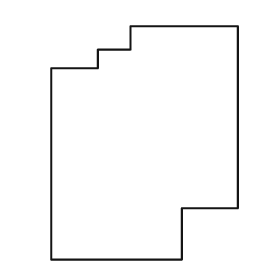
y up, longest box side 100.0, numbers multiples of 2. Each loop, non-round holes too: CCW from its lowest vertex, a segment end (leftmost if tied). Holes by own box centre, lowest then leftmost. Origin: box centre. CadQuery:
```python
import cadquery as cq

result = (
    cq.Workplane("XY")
    .moveTo(-40.0, -50.0)
    .lineTo(16.0, -50.0)
    .lineTo(16.0, -28.0)
    .lineTo(40.0, -28.0)
    .lineTo(40.0, 50.0)
    .lineTo(-6.0, 50.0)
    .lineTo(-6.0, 40.0)
    .lineTo(-20.0, 40.0)
    .lineTo(-20.0, 32.0)
    .lineTo(-40.0, 32.0)
    .close()
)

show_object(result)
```